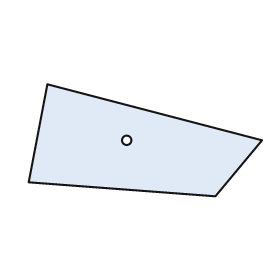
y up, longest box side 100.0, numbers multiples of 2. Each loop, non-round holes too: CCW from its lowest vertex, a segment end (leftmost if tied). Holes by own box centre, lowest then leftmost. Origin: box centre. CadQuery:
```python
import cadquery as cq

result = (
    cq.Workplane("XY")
    .moveTo(30.0, -24.0)
    .lineTo(50.0, 0.0)
    .lineTo(-42.0, 24.0)
    .lineTo(-50.0, -18.0)
    .close()
    .moveTo(-8.0, 0.0)
    .circle(2.0)
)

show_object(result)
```